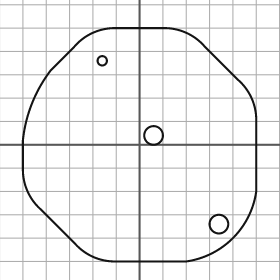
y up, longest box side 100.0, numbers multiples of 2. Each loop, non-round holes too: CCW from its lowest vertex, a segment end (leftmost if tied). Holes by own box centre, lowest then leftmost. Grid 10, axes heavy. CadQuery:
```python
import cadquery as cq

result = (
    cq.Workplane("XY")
    .moveTo(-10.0, -50.0)
    .lineTo(20.0, -50.0)
    .threePointArc((40.0, -40.0), (50.0, -20.0))
    .lineTo(50.0, 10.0)
    .threePointArc((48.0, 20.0), (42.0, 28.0))
    .lineTo(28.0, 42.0)
    .threePointArc((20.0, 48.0), (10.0, 50.0))
    .lineTo(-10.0, 50.0)
    .threePointArc((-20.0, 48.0), (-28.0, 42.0))
    .lineTo(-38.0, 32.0)
    .threePointArc((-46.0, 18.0), (-50.0, 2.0))
    .lineTo(-50.0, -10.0)
    .threePointArc((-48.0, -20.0), (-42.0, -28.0))
    .lineTo(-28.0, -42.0)
    .threePointArc((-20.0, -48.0), (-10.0, -50.0))
    .close()
    .moveTo(34.0, -34.0)
    .circle(4.0)
    .moveTo(6.0, 4.0)
    .circle(4.0)
    .moveTo(-16.0, 36.0)
    .circle(2.0)
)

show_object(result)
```